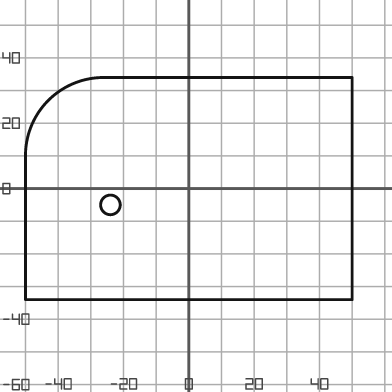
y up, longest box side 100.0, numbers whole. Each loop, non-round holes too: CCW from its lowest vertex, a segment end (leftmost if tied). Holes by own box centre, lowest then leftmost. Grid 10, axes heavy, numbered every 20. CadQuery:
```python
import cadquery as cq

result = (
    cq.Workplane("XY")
    .moveTo(-50.0, -34.0)
    .lineTo(50.0, -34.0)
    .lineTo(50.0, 34.0)
    .lineTo(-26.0, 34.0)
    .threePointArc((-43.0, 27.0), (-50.0, 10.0))
    .close()
    .moveTo(-24.0, -5.0)
    .circle(3.0)
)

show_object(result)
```